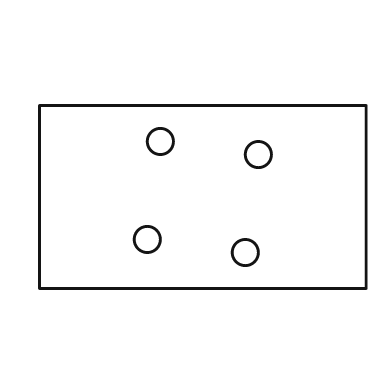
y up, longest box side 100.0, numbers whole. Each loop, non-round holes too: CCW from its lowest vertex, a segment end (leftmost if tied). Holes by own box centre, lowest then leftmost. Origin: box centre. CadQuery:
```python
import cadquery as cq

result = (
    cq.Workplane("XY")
    .moveTo(-50.0, -28.0)
    .lineTo(50.0, -28.0)
    .lineTo(50.0, 28.0)
    .lineTo(-50.0, 28.0)
    .close()
    .moveTo(13.0, -17.0)
    .circle(4.0)
    .moveTo(-17.0, -13.0)
    .circle(4.0)
    .moveTo(17.0, 13.0)
    .circle(4.0)
    .moveTo(-13.0, 17.0)
    .circle(4.0)
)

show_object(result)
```